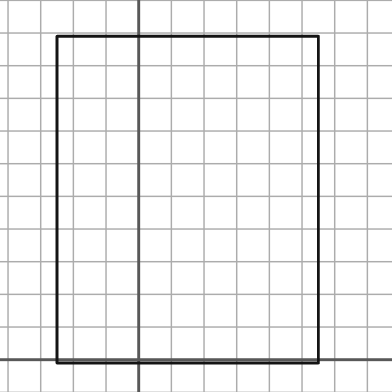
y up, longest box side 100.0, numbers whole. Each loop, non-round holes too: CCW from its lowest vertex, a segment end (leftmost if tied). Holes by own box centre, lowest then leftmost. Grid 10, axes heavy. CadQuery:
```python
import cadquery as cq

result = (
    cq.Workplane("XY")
    .moveTo(-25.0, -1.0)
    .lineTo(55.0, -1.0)
    .lineTo(55.0, 99.0)
    .lineTo(-25.0, 99.0)
    .close()
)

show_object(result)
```